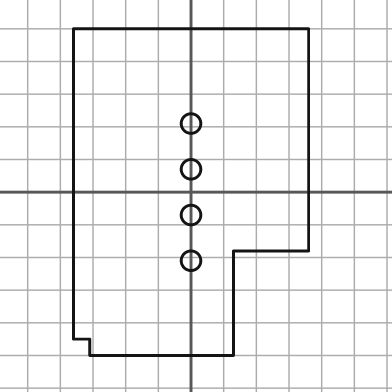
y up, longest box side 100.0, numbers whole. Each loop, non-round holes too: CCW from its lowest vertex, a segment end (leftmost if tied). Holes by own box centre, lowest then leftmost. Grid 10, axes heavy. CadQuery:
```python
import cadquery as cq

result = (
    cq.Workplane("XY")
    .moveTo(-31.0, -50.0)
    .lineTo(13.0, -50.0)
    .lineTo(13.0, -18.0)
    .lineTo(36.0, -18.0)
    .lineTo(36.0, 50.0)
    .lineTo(-36.0, 50.0)
    .lineTo(-36.0, -45.0)
    .lineTo(-31.0, -45.0)
    .close()
    .moveTo(0.0, -21.0)
    .circle(3.0)
    .moveTo(0.0, -7.0)
    .circle(3.0)
    .moveTo(0.0, 7.0)
    .circle(3.0)
    .moveTo(0.0, 21.0)
    .circle(3.0)
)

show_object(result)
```